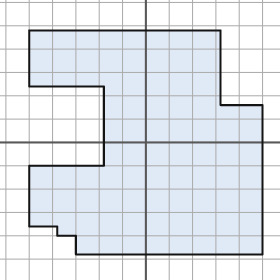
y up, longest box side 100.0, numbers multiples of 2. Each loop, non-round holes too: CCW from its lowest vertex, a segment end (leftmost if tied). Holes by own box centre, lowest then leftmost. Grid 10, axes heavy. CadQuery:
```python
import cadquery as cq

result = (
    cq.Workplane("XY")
    .moveTo(-30.0, -48.0)
    .lineTo(50.0, -48.0)
    .lineTo(50.0, 16.0)
    .lineTo(32.0, 16.0)
    .lineTo(32.0, 48.0)
    .lineTo(-50.0, 48.0)
    .lineTo(-50.0, 24.0)
    .lineTo(-18.0, 24.0)
    .lineTo(-18.0, -10.0)
    .lineTo(-50.0, -10.0)
    .lineTo(-50.0, -36.0)
    .lineTo(-38.0, -36.0)
    .lineTo(-38.0, -40.0)
    .lineTo(-30.0, -40.0)
    .close()
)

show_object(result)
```